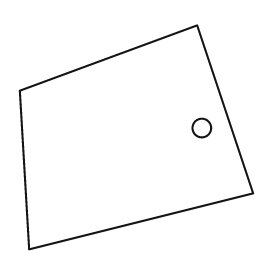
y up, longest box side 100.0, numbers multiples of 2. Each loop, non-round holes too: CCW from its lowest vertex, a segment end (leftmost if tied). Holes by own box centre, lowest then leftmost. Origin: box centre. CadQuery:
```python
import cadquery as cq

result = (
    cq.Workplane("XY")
    .moveTo(-46.0, -48.0)
    .lineTo(50.0, -24.0)
    .lineTo(26.0, 48.0)
    .lineTo(-50.0, 20.0)
    .close()
    .moveTo(28.0, 4.0)
    .circle(4.0)
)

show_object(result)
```